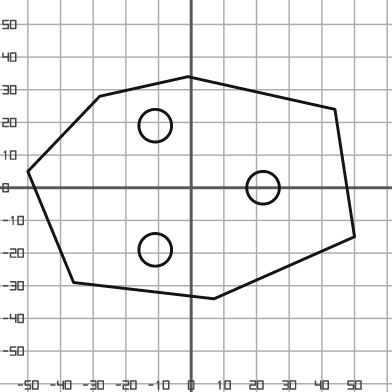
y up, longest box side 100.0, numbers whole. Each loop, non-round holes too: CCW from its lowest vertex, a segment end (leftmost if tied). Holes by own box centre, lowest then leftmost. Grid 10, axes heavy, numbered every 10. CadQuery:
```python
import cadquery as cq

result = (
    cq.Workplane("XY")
    .moveTo(7.0, -34.0)
    .lineTo(50.0, -15.0)
    .lineTo(44.0, 24.0)
    .lineTo(-1.0, 34.0)
    .lineTo(-28.0, 28.0)
    .lineTo(-50.0, 5.0)
    .lineTo(-36.0, -29.0)
    .close()
    .moveTo(-11.0, -19.0)
    .circle(5.0)
    .moveTo(22.0, 0.0)
    .circle(5.0)
    .moveTo(-11.0, 19.0)
    .circle(5.0)
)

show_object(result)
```